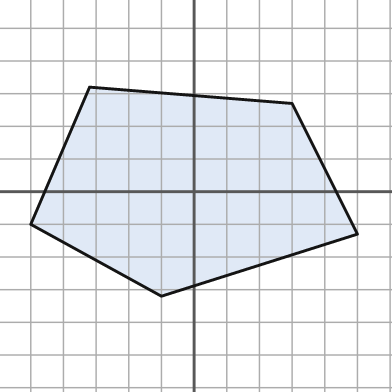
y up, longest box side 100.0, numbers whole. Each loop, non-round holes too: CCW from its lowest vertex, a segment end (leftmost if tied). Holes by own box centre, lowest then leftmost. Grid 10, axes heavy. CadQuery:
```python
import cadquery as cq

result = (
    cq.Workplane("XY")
    .moveTo(-10.0, -32.0)
    .lineTo(50.0, -13.0)
    .lineTo(30.0, 27.0)
    .lineTo(-32.0, 32.0)
    .lineTo(-50.0, -10.0)
    .close()
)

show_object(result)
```